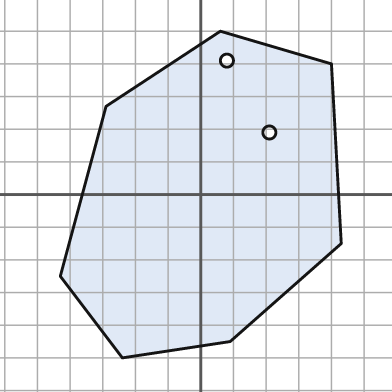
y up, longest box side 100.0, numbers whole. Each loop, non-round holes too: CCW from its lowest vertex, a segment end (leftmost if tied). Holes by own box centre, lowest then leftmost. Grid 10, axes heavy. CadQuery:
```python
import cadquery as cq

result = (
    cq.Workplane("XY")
    .moveTo(-24.0, -50.0)
    .lineTo(9.0, -45.0)
    .lineTo(43.0, -15.0)
    .lineTo(40.0, 40.0)
    .lineTo(6.0, 50.0)
    .lineTo(-29.0, 27.0)
    .lineTo(-43.0, -25.0)
    .close()
    .moveTo(21.0, 19.0)
    .circle(2.0)
    .moveTo(8.0, 41.0)
    .circle(2.0)
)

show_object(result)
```